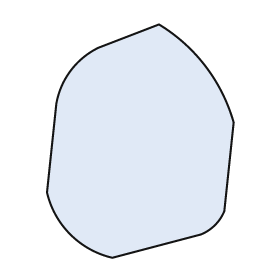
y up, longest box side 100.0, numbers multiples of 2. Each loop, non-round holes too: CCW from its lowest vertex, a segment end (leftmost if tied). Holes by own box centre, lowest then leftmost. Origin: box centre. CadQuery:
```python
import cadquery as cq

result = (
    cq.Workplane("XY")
    .moveTo(-12.0, -50.0)
    .lineTo(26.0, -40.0)
    .threePointArc((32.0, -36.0), (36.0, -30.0))
    .lineTo(40.0, 8.0)
    .threePointArc((28.0, 32.0), (8.0, 50.0))
    .lineTo(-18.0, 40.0)
    .threePointArc((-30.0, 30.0), (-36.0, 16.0))
    .lineTo(-40.0, -22.0)
    .threePointArc((-30.0, -40.0), (-12.0, -50.0))
    .close()
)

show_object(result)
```